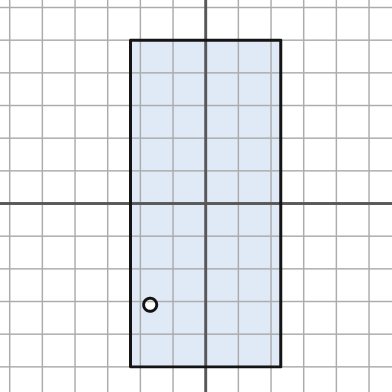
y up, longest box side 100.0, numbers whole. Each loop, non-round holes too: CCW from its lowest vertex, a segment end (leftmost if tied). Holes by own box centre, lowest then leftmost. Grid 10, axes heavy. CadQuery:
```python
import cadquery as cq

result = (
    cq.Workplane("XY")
    .moveTo(-23.0, -50.0)
    .lineTo(23.0, -50.0)
    .lineTo(23.0, 50.0)
    .lineTo(-23.0, 50.0)
    .close()
    .moveTo(-17.0, -31.0)
    .circle(2.0)
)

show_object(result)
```